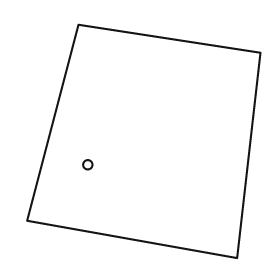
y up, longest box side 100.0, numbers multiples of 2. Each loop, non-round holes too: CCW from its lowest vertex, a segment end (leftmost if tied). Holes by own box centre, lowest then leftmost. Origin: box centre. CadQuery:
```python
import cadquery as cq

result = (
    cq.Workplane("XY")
    .moveTo(40.0, -50.0)
    .lineTo(50.0, 38.0)
    .lineTo(-28.0, 50.0)
    .lineTo(-50.0, -34.0)
    .close()
    .moveTo(-24.0, -10.0)
    .circle(2.0)
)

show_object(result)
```